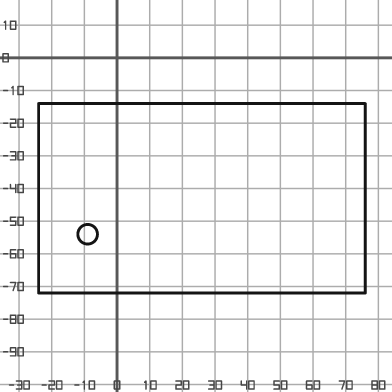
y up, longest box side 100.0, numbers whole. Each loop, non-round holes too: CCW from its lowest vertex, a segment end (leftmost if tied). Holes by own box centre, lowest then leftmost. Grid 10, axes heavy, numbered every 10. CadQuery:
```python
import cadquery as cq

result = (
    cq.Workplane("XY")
    .moveTo(-24.0, -72.0)
    .lineTo(76.0, -72.0)
    .lineTo(76.0, -14.0)
    .lineTo(-24.0, -14.0)
    .close()
    .moveTo(-9.0, -54.0)
    .circle(3.0)
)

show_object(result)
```